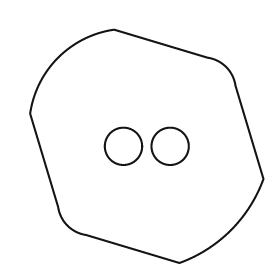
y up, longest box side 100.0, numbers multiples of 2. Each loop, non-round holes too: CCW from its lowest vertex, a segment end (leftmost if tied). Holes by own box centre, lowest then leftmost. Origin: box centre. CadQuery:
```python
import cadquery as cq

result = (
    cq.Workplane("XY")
    .moveTo(14.0, -50.0)
    .threePointArc((36.0, -36.0), (50.0, -14.0))
    .lineTo(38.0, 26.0)
    .threePointArc((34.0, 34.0), (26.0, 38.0))
    .lineTo(-14.0, 50.0)
    .threePointArc((-38.0, 38.0), (-50.0, 14.0))
    .lineTo(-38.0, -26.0)
    .threePointArc((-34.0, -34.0), (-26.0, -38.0))
    .close()
    .moveTo(-10.0, 0.0)
    .circle(8.0)
    .moveTo(10.0, 0.0)
    .circle(8.0)
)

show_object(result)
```